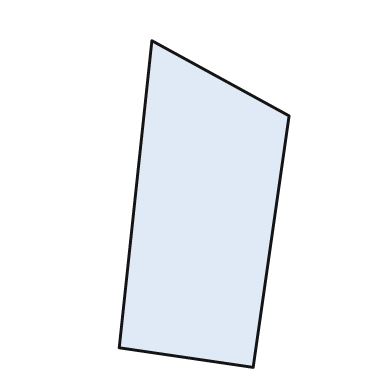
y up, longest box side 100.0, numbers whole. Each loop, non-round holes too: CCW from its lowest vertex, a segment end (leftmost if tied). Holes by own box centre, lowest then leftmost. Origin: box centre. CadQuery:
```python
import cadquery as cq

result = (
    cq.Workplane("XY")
    .moveTo(15.0, -50.0)
    .lineTo(26.0, 27.0)
    .lineTo(-16.0, 50.0)
    .lineTo(-26.0, -44.0)
    .close()
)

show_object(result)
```